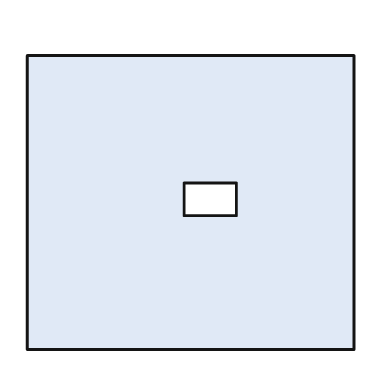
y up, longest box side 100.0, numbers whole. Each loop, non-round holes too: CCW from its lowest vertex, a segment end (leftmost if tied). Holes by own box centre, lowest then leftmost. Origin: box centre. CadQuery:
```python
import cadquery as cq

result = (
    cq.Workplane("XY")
    .moveTo(-50.0, -45.0)
    .lineTo(50.0, -45.0)
    .lineTo(50.0, 45.0)
    .lineTo(-50.0, 45.0)
    .close()
    .moveTo(-2.0, -4.0)
    .lineTo(14.0, -4.0)
    .lineTo(14.0, 6.0)
    .lineTo(-2.0, 6.0)
    .close()
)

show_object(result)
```